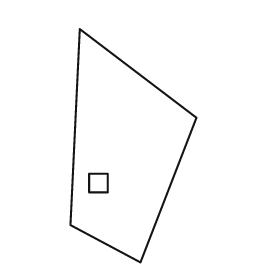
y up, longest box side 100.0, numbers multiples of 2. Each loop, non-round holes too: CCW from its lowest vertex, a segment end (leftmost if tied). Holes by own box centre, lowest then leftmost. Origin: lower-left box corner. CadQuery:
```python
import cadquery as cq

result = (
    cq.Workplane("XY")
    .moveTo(30.0, 0.0)
    .lineTo(54.0, 62.0)
    .lineTo(4.0, 100.0)
    .lineTo(0.0, 16.0)
    .close()
    .moveTo(8.0, 30.0)
    .lineTo(16.0, 30.0)
    .lineTo(16.0, 38.0)
    .lineTo(8.0, 38.0)
    .close()
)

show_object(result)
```